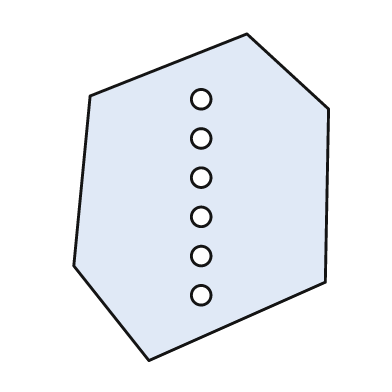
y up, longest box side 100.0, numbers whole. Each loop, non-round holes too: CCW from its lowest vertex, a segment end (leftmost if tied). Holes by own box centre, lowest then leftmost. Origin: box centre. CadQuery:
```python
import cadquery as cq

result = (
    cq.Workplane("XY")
    .moveTo(-16.0, -50.0)
    .lineTo(38.0, -26.0)
    .lineTo(39.0, 27.0)
    .lineTo(14.0, 50.0)
    .lineTo(-34.0, 31.0)
    .lineTo(-39.0, -21.0)
    .close()
    .moveTo(0.0, -30.0)
    .circle(3.0)
    .moveTo(0.0, -18.0)
    .circle(3.0)
    .moveTo(0.0, -6.0)
    .circle(3.0)
    .moveTo(0.0, 6.0)
    .circle(3.0)
    .moveTo(0.0, 18.0)
    .circle(3.0)
    .moveTo(0.0, 30.0)
    .circle(3.0)
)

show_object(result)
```